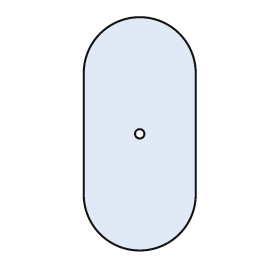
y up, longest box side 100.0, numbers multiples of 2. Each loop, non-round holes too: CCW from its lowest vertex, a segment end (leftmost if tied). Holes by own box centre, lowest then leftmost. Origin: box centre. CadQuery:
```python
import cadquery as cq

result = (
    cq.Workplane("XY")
    .moveTo(-24.0, -26.0)
    .threePointArc((0.0, -50.0), (24.0, -26.0))
    .lineTo(24.0, 26.0)
    .threePointArc((0.0, 50.0), (-24.0, 26.0))
    .close()
    .moveTo(0.0, 0.0)
    .circle(2.0)
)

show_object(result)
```